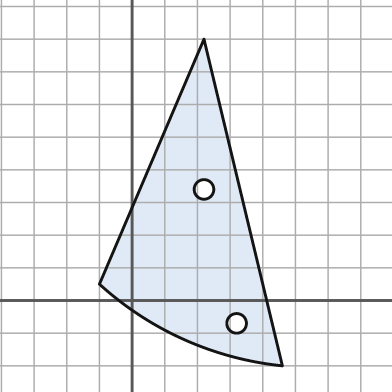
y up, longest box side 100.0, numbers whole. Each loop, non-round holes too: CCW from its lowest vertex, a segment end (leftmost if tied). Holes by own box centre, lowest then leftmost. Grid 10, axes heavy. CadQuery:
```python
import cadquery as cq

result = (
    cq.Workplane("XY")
    .moveTo(46.0, -20.0)
    .lineTo(22.0, 80.0)
    .lineTo(-10.0, 5.0)
    .threePointArc((16.0, -12.0), (46.0, -20.0))
    .close()
    .moveTo(32.0, -7.0)
    .circle(3.0)
    .moveTo(22.0, 34.0)
    .circle(3.0)
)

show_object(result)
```